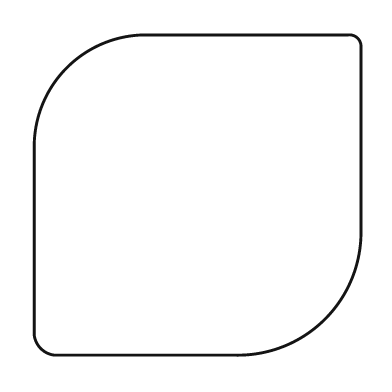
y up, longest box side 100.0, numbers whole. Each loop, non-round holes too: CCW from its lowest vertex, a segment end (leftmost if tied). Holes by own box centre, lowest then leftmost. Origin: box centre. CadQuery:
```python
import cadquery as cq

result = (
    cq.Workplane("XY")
    .moveTo(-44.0, -49.0)
    .lineTo(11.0, -49.0)
    .threePointArc((39.0, -38.0), (50.0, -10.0))
    .lineTo(50.0, 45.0)
    .threePointArc((49.0, 48.0), (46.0, 49.0))
    .lineTo(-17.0, 49.0)
    .threePointArc((-40.0, 39.0), (-50.0, 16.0))
    .lineTo(-50.0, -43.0)
    .threePointArc((-48.0, -47.0), (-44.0, -49.0))
    .close()
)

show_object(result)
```